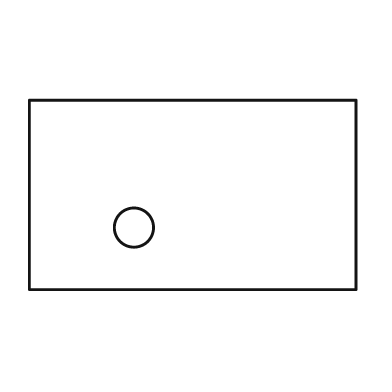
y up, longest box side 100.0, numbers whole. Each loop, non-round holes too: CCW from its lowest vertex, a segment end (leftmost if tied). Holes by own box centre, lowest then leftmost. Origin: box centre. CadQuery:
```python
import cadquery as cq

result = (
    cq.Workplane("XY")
    .moveTo(-50.0, -29.0)
    .lineTo(50.0, -29.0)
    .lineTo(50.0, 29.0)
    .lineTo(-50.0, 29.0)
    .close()
    .moveTo(-18.0, -10.0)
    .circle(6.0)
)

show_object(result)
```